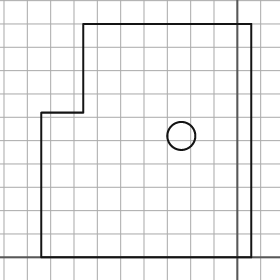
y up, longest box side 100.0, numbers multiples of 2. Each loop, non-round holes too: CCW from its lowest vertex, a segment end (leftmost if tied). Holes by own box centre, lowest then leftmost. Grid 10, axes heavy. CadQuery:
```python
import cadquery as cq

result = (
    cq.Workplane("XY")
    .moveTo(-84.0, 0.0)
    .lineTo(6.0, 0.0)
    .lineTo(6.0, 100.0)
    .lineTo(-66.0, 100.0)
    .lineTo(-66.0, 62.0)
    .lineTo(-84.0, 62.0)
    .close()
    .moveTo(-24.0, 52.0)
    .circle(6.0)
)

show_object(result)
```